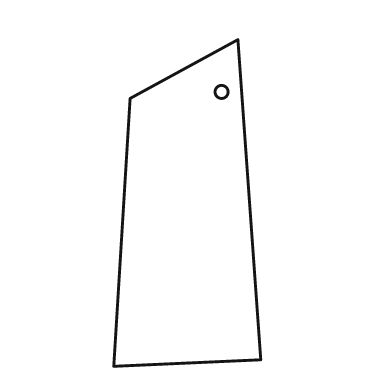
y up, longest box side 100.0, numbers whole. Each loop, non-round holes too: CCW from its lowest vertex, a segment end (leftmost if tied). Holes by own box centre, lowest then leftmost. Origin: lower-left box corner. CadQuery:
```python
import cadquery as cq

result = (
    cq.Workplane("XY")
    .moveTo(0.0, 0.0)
    .lineTo(45.0, 2.0)
    .lineTo(38.0, 100.0)
    .lineTo(5.0, 82.0)
    .close()
    .moveTo(33.0, 84.0)
    .circle(2.0)
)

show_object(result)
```